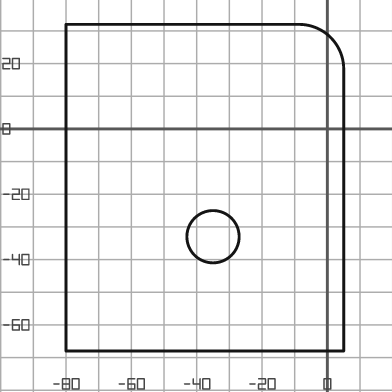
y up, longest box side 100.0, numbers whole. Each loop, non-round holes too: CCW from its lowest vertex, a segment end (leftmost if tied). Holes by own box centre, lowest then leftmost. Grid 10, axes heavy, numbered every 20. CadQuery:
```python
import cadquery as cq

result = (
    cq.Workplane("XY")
    .moveTo(-80.0, -68.0)
    .lineTo(5.0, -68.0)
    .lineTo(5.0, 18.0)
    .threePointArc((1.0, 28.0), (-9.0, 32.0))
    .lineTo(-80.0, 32.0)
    .close()
    .moveTo(-35.0, -33.0)
    .circle(8.0)
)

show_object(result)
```